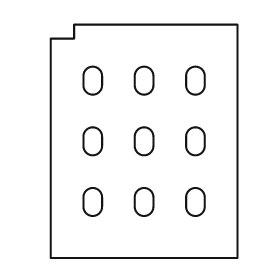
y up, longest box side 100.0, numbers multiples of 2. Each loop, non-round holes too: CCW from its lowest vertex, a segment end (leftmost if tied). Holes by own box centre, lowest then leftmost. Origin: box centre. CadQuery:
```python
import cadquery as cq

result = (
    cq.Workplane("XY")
    .moveTo(-40.0, -50.0)
    .lineTo(40.0, -50.0)
    .lineTo(40.0, 50.0)
    .lineTo(-30.0, 50.0)
    .lineTo(-30.0, 44.0)
    .lineTo(-40.0, 44.0)
    .close()
    .moveTo(-26.0, -28.0)
    .threePointArc((-22.0, -32.0), (-18.0, -28.0))
    .lineTo(-18.0, -24.0)
    .threePointArc((-22.0, -20.0), (-26.0, -24.0))
    .close()
    .moveTo(-4.0, -28.0)
    .threePointArc((0.0, -32.0), (4.0, -28.0))
    .lineTo(4.0, -24.0)
    .threePointArc((0.0, -20.0), (-4.0, -24.0))
    .close()
    .moveTo(18.0, -28.0)
    .threePointArc((22.0, -32.0), (26.0, -28.0))
    .lineTo(26.0, -24.0)
    .threePointArc((22.0, -20.0), (18.0, -24.0))
    .close()
    .moveTo(-26.0, -2.0)
    .threePointArc((-22.0, -6.0), (-18.0, -2.0))
    .lineTo(-18.0, 2.0)
    .threePointArc((-22.0, 6.0), (-26.0, 2.0))
    .close()
    .moveTo(-4.0, -2.0)
    .threePointArc((0.0, -6.0), (4.0, -2.0))
    .lineTo(4.0, 2.0)
    .threePointArc((0.0, 6.0), (-4.0, 2.0))
    .close()
    .moveTo(18.0, -2.0)
    .threePointArc((22.0, -6.0), (26.0, -2.0))
    .lineTo(26.0, 2.0)
    .threePointArc((22.0, 6.0), (18.0, 2.0))
    .close()
    .moveTo(-26.0, 24.0)
    .threePointArc((-22.0, 20.0), (-18.0, 24.0))
    .lineTo(-18.0, 28.0)
    .threePointArc((-22.0, 32.0), (-26.0, 28.0))
    .close()
    .moveTo(-4.0, 24.0)
    .threePointArc((0.0, 20.0), (4.0, 24.0))
    .lineTo(4.0, 28.0)
    .threePointArc((0.0, 32.0), (-4.0, 28.0))
    .close()
    .moveTo(18.0, 24.0)
    .threePointArc((22.0, 20.0), (26.0, 24.0))
    .lineTo(26.0, 28.0)
    .threePointArc((22.0, 32.0), (18.0, 28.0))
    .close()
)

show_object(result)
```